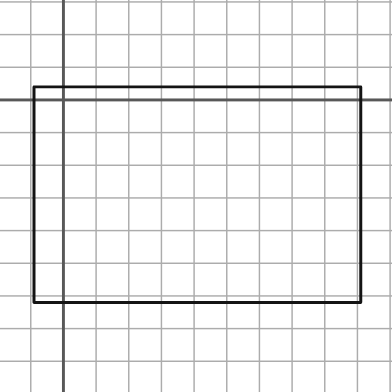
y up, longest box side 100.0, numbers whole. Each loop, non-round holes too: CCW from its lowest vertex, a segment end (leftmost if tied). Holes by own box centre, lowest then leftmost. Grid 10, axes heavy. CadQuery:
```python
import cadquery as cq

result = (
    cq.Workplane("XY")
    .moveTo(-9.0, -62.0)
    .lineTo(91.0, -62.0)
    .lineTo(91.0, 4.0)
    .lineTo(-9.0, 4.0)
    .close()
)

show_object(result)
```